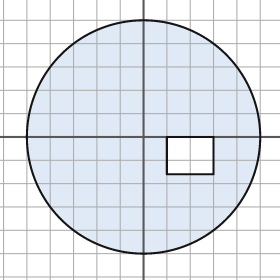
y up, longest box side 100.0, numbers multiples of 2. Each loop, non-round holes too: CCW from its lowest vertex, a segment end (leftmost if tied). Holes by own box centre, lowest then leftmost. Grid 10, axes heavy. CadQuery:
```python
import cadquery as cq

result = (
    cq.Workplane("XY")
    .moveTo(0.0, 0.0)
    .circle(50.0)
    .moveTo(10.0, -16.0)
    .lineTo(30.0, -16.0)
    .lineTo(30.0, 0.0)
    .lineTo(10.0, 0.0)
    .close()
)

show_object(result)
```